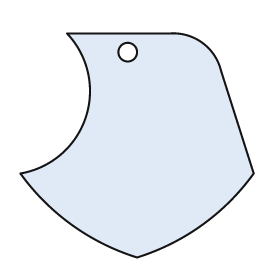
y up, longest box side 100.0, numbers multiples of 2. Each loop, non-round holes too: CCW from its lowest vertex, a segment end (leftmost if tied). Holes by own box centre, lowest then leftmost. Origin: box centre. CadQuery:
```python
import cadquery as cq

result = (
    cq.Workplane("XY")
    .moveTo(0.0, -48.0)
    .threePointArc((28.0, -34.0), (50.0, -12.0))
    .lineTo(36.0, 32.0)
    .threePointArc((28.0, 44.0), (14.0, 48.0))
    .lineTo(-30.0, 48.0)
    .threePointArc((-22.0, 12.0), (-50.0, -12.0))
    .threePointArc((-28.0, -34.0), (0.0, -48.0))
    .close()
    .moveTo(-4.0, 40.0)
    .circle(4.0)
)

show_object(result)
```